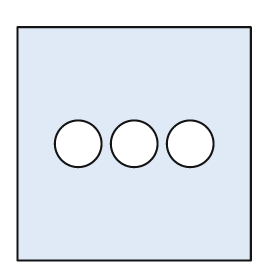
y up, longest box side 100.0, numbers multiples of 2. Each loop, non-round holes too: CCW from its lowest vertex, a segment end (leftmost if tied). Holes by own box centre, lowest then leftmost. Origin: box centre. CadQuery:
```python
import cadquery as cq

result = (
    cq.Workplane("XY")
    .moveTo(-50.0, -50.0)
    .lineTo(50.0, -50.0)
    .lineTo(50.0, 50.0)
    .lineTo(-50.0, 50.0)
    .close()
    .moveTo(-24.0, 0.0)
    .circle(10.0)
    .moveTo(0.0, 0.0)
    .circle(10.0)
    .moveTo(24.0, 0.0)
    .circle(10.0)
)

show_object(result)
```